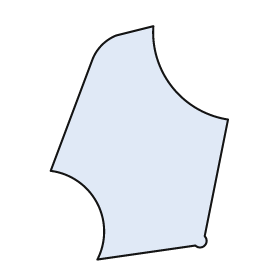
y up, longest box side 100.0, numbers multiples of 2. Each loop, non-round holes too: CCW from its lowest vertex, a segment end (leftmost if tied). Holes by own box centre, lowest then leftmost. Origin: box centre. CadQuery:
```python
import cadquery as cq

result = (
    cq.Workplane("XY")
    .moveTo(-18.0, -50.0)
    .lineTo(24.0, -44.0)
    .threePointArc((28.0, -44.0), (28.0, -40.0))
    .lineTo(38.0, 10.0)
    .threePointArc((14.0, 24.0), (6.0, 50.0))
    .lineTo(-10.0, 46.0)
    .threePointArc((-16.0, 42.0), (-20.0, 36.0))
    .lineTo(-38.0, -12.0)
    .threePointArc((-18.0, -26.0), (-18.0, -50.0))
    .close()
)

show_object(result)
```